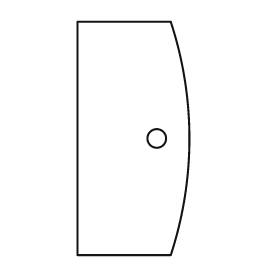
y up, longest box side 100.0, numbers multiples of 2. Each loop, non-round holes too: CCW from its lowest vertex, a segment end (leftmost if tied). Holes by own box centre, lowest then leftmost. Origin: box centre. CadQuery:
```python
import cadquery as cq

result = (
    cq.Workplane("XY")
    .moveTo(-24.0, -50.0)
    .lineTo(16.0, -50.0)
    .threePointArc((24.0, 0.0), (16.0, 50.0))
    .lineTo(-24.0, 50.0)
    .close()
    .moveTo(10.0, 0.0)
    .circle(4.0)
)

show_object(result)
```